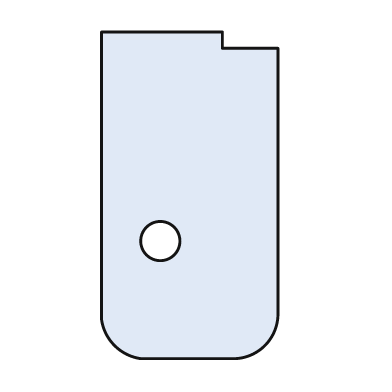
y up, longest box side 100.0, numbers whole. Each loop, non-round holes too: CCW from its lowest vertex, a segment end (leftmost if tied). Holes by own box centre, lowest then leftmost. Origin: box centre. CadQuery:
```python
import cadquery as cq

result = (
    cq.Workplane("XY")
    .moveTo(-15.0, -50.0)
    .lineTo(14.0, -50.0)
    .threePointArc((23.0, -46.0), (27.0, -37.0))
    .lineTo(27.0, 45.0)
    .lineTo(10.0, 45.0)
    .lineTo(10.0, 50.0)
    .lineTo(-27.0, 50.0)
    .lineTo(-27.0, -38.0)
    .threePointArc((-23.0, -46.0), (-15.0, -50.0))
    .close()
    .moveTo(-9.0, -14.0)
    .circle(6.0)
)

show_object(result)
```